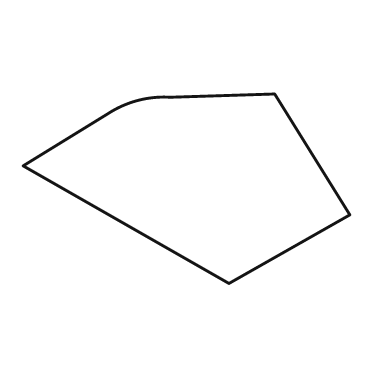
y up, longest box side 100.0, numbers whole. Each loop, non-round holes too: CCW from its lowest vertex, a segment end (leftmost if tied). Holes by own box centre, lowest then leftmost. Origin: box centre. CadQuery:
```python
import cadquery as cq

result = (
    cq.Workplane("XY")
    .moveTo(13.0, -29.0)
    .lineTo(50.0, -8.0)
    .lineTo(27.0, 29.0)
    .lineTo(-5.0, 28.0)
    .threePointArc((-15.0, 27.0), (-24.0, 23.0))
    .lineTo(-50.0, 7.0)
    .close()
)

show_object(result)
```